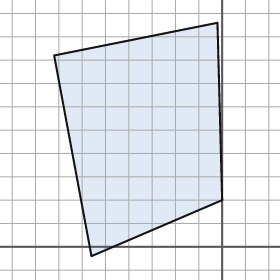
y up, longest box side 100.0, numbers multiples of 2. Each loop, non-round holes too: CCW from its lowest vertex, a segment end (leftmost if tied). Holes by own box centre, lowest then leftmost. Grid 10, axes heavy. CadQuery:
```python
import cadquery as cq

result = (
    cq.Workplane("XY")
    .moveTo(-56.0, -4.0)
    .lineTo(0.0, 20.0)
    .lineTo(-2.0, 96.0)
    .lineTo(-72.0, 82.0)
    .close()
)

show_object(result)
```